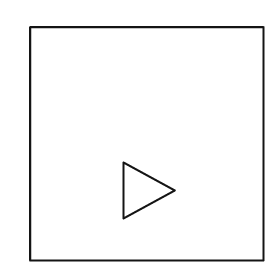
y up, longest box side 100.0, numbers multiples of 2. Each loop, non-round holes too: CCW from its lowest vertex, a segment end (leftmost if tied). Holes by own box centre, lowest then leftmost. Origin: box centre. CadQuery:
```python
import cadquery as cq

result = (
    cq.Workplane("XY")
    .moveTo(-50.0, -50.0)
    .lineTo(50.0, -50.0)
    .lineTo(50.0, 50.0)
    .lineTo(-50.0, 50.0)
    .close()
    .moveTo(-10.0, -32.0)
    .lineTo(12.0, -20.0)
    .lineTo(-10.0, -8.0)
    .close()
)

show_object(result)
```